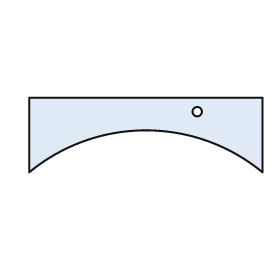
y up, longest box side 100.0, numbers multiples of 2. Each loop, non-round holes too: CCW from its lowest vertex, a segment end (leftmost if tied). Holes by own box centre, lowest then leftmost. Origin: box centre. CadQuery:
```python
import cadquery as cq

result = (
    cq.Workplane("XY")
    .moveTo(-50.0, -16.0)
    .threePointArc((0.0, 2.0), (50.0, -16.0))
    .lineTo(50.0, 16.0)
    .lineTo(-50.0, 16.0)
    .close()
    .moveTo(22.0, 10.0)
    .circle(2.0)
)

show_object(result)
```